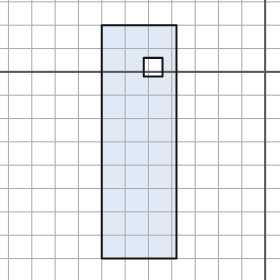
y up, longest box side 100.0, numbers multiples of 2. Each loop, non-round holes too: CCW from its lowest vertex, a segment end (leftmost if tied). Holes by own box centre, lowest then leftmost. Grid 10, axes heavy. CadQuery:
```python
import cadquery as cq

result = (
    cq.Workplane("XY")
    .moveTo(-70.0, -80.0)
    .lineTo(-38.0, -80.0)
    .lineTo(-38.0, 20.0)
    .lineTo(-70.0, 20.0)
    .close()
    .moveTo(-52.0, -2.0)
    .lineTo(-44.0, -2.0)
    .lineTo(-44.0, 6.0)
    .lineTo(-52.0, 6.0)
    .close()
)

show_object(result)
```